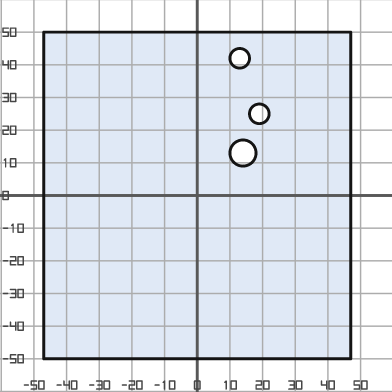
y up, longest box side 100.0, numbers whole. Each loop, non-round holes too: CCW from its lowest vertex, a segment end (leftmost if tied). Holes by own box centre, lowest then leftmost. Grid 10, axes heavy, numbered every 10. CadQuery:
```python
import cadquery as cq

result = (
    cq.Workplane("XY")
    .moveTo(-47.0, -50.0)
    .lineTo(47.0, -50.0)
    .lineTo(47.0, 50.0)
    .lineTo(-47.0, 50.0)
    .close()
    .moveTo(14.0, 13.0)
    .circle(4.0)
    .moveTo(19.0, 25.0)
    .circle(3.0)
    .moveTo(13.0, 42.0)
    .circle(3.0)
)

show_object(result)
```